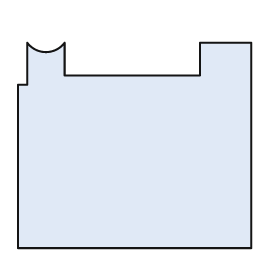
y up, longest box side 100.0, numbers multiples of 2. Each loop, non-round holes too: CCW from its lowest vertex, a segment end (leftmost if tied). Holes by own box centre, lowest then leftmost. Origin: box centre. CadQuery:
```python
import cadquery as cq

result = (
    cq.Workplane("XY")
    .moveTo(-50.0, -44.0)
    .lineTo(50.0, -44.0)
    .lineTo(50.0, 44.0)
    .lineTo(28.0, 44.0)
    .lineTo(28.0, 30.0)
    .lineTo(-30.0, 30.0)
    .lineTo(-30.0, 44.0)
    .threePointArc((-38.0, 40.0), (-46.0, 44.0))
    .lineTo(-46.0, 26.0)
    .lineTo(-50.0, 26.0)
    .close()
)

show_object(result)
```